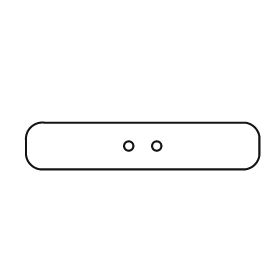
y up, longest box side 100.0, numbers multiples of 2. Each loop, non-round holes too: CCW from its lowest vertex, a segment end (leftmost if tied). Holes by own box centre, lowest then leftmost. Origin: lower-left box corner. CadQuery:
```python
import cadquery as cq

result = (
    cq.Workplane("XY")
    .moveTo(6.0, 0.0)
    .lineTo(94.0, 0.0)
    .threePointArc((98.0, 2.0), (100.0, 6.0))
    .lineTo(100.0, 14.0)
    .threePointArc((98.0, 18.0), (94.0, 20.0))
    .lineTo(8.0, 20.0)
    .threePointArc((2.0, 18.0), (0.0, 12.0))
    .lineTo(0.0, 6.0)
    .threePointArc((2.0, 2.0), (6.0, 0.0))
    .close()
    .moveTo(44.0, 10.0)
    .circle(2.0)
    .moveTo(56.0, 10.0)
    .circle(2.0)
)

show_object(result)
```